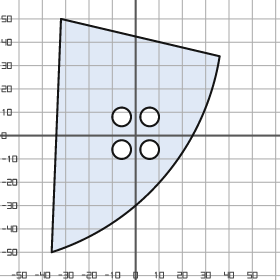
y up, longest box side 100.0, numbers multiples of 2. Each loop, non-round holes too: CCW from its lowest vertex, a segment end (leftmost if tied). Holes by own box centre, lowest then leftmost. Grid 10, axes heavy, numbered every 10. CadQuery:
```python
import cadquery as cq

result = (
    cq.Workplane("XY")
    .moveTo(-36.0, -50.0)
    .threePointArc((12.0, -18.0), (36.0, 34.0))
    .lineTo(-32.0, 50.0)
    .close()
    .moveTo(-6.0, -6.0)
    .circle(4.0)
    .moveTo(6.0, -6.0)
    .circle(4.0)
    .moveTo(-6.0, 8.0)
    .circle(4.0)
    .moveTo(6.0, 8.0)
    .circle(4.0)
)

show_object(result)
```